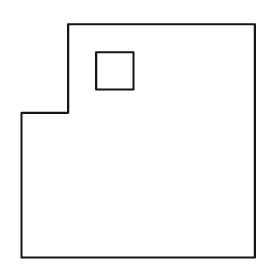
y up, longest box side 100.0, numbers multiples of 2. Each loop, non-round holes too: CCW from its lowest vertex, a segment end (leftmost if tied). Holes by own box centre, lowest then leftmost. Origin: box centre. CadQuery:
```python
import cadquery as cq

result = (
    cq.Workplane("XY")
    .moveTo(-50.0, -50.0)
    .lineTo(50.0, -50.0)
    .lineTo(50.0, 50.0)
    .lineTo(-30.0, 50.0)
    .lineTo(-30.0, 12.0)
    .lineTo(-50.0, 12.0)
    .close()
    .moveTo(-18.0, 22.0)
    .lineTo(-2.0, 22.0)
    .lineTo(-2.0, 38.0)
    .lineTo(-18.0, 38.0)
    .close()
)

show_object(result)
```